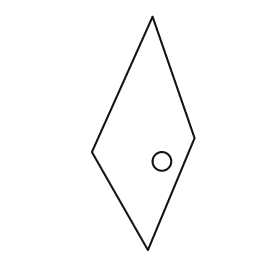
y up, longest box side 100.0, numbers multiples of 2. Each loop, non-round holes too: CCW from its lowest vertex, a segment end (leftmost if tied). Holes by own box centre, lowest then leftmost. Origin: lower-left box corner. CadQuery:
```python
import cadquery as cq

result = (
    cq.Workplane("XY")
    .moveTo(24.0, 0.0)
    .lineTo(44.0, 48.0)
    .lineTo(26.0, 100.0)
    .lineTo(0.0, 42.0)
    .close()
    .moveTo(30.0, 38.0)
    .circle(4.0)
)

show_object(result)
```